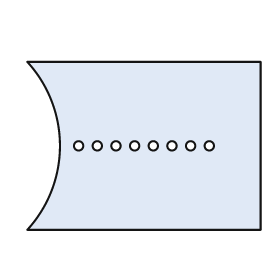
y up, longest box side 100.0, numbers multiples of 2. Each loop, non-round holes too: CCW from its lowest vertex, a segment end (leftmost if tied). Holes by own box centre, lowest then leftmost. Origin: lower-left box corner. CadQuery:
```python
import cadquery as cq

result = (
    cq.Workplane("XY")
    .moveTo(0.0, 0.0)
    .lineTo(100.0, 0.0)
    .lineTo(100.0, 72.0)
    .lineTo(0.0, 72.0)
    .threePointArc((14.0, 36.0), (0.0, 0.0))
    .close()
    .moveTo(22.0, 36.0)
    .circle(2.0)
    .moveTo(30.0, 36.0)
    .circle(2.0)
    .moveTo(38.0, 36.0)
    .circle(2.0)
    .moveTo(46.0, 36.0)
    .circle(2.0)
    .moveTo(54.0, 36.0)
    .circle(2.0)
    .moveTo(62.0, 36.0)
    .circle(2.0)
    .moveTo(70.0, 36.0)
    .circle(2.0)
    .moveTo(78.0, 36.0)
    .circle(2.0)
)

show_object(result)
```